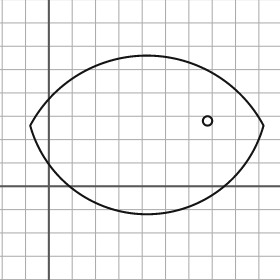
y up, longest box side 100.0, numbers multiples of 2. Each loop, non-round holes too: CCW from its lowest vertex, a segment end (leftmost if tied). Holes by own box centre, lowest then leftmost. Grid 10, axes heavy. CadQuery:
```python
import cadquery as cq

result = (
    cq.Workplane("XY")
    .moveTo(-8.0, 26.0)
    .threePointArc((42.0, -12.0), (92.0, 26.0))
    .threePointArc((42.0, 56.0), (-8.0, 26.0))
    .close()
    .moveTo(68.0, 28.0)
    .circle(2.0)
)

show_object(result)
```